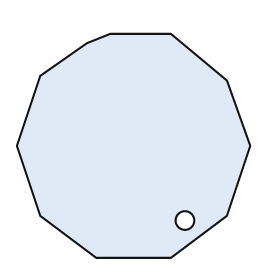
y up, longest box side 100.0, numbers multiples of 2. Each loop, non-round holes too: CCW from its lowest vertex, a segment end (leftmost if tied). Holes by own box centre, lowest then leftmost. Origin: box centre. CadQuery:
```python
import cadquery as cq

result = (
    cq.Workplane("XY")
    .moveTo(-16.0, -48.0)
    .lineTo(16.0, -48.0)
    .lineTo(40.0, -30.0)
    .lineTo(50.0, 0.0)
    .lineTo(40.0, 28.0)
    .lineTo(16.0, 48.0)
    .lineTo(-10.0, 48.0)
    .lineTo(-20.0, 44.0)
    .lineTo(-40.0, 30.0)
    .lineTo(-50.0, 0.0)
    .lineTo(-40.0, -30.0)
    .close()
    .moveTo(22.0, -32.0)
    .circle(4.0)
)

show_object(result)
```